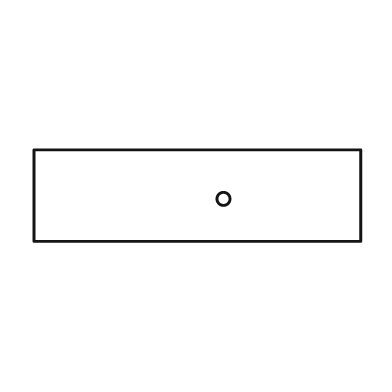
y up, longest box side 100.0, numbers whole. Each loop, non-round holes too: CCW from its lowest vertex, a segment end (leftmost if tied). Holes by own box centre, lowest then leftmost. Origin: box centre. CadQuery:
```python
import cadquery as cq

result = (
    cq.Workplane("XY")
    .moveTo(-50.0, -14.0)
    .lineTo(50.0, -14.0)
    .lineTo(50.0, 14.0)
    .lineTo(-50.0, 14.0)
    .close()
    .moveTo(8.0, -1.0)
    .circle(2.0)
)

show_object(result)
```